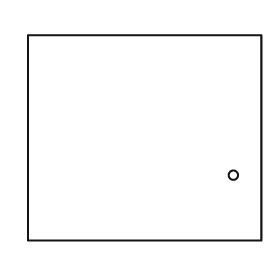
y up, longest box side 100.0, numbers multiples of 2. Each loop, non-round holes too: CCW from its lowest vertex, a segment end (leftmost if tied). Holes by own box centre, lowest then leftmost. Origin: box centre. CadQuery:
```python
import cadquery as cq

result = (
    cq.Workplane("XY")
    .moveTo(-50.0, -44.0)
    .lineTo(50.0, -44.0)
    .lineTo(50.0, 44.0)
    .lineTo(-50.0, 44.0)
    .close()
    .moveTo(38.0, -16.0)
    .circle(2.0)
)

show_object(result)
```